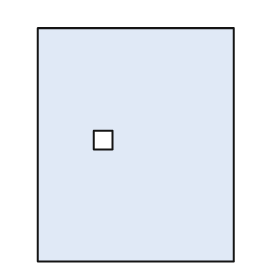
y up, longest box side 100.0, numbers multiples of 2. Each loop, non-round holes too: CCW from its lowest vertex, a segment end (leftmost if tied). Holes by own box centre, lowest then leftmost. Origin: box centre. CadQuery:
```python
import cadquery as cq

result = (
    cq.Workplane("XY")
    .moveTo(-42.0, -50.0)
    .lineTo(42.0, -50.0)
    .lineTo(42.0, 50.0)
    .lineTo(-42.0, 50.0)
    .close()
    .moveTo(-18.0, -2.0)
    .lineTo(-10.0, -2.0)
    .lineTo(-10.0, 6.0)
    .lineTo(-18.0, 6.0)
    .close()
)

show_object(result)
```